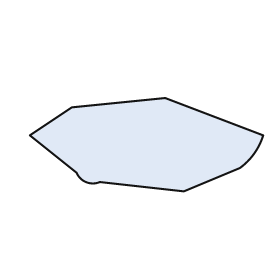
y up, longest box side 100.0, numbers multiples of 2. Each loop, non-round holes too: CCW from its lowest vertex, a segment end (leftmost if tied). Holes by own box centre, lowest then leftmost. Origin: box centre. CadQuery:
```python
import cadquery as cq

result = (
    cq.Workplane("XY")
    .moveTo(16.0, -20.0)
    .lineTo(40.0, -10.0)
    .threePointArc((46.0, -4.0), (50.0, 4.0))
    .lineTo(8.0, 20.0)
    .lineTo(-32.0, 16.0)
    .lineTo(-50.0, 4.0)
    .lineTo(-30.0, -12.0)
    .threePointArc((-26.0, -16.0), (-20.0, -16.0))
    .close()
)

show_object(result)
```